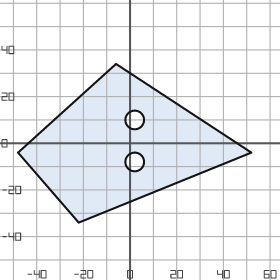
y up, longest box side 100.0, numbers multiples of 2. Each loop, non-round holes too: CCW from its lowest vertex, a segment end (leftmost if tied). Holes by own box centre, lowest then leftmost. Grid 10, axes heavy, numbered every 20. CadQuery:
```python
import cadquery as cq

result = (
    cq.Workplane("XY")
    .moveTo(-22.0, -34.0)
    .lineTo(52.0, -4.0)
    .lineTo(-6.0, 34.0)
    .lineTo(-48.0, -4.0)
    .close()
    .moveTo(2.0, -8.0)
    .circle(4.0)
    .moveTo(2.0, 10.0)
    .circle(4.0)
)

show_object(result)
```